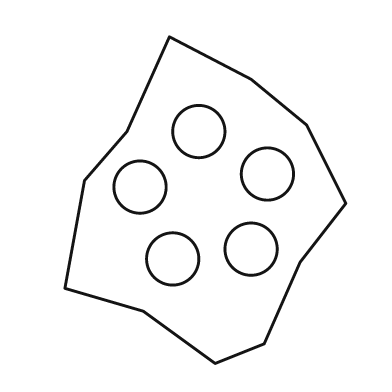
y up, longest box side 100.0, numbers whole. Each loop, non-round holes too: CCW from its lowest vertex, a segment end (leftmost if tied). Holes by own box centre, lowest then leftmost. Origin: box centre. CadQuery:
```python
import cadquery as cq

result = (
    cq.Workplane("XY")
    .moveTo(3.0, -50.0)
    .lineTo(18.0, -44.0)
    .lineTo(29.0, -19.0)
    .lineTo(43.0, -1.0)
    .lineTo(31.0, 23.0)
    .lineTo(14.0, 37.0)
    .lineTo(-11.0, 50.0)
    .lineTo(-24.0, 21.0)
    .lineTo(-37.0, 6.0)
    .lineTo(-43.0, -27.0)
    .lineTo(-19.0, -34.0)
    .close()
    .moveTo(-10.0, -18.0)
    .circle(8.0)
    .moveTo(14.0, -15.0)
    .circle(8.0)
    .moveTo(-20.0, 4.0)
    .circle(8.0)
    .moveTo(19.0, 8.0)
    .circle(8.0)
    .moveTo(-2.0, 21.0)
    .circle(8.0)
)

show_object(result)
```